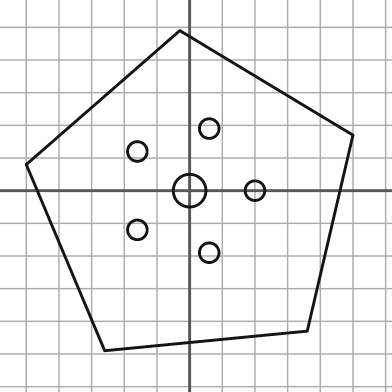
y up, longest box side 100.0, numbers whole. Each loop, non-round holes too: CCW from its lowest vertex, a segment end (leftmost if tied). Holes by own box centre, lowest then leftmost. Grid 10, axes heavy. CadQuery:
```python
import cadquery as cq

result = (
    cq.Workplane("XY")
    .moveTo(-26.0, -49.0)
    .lineTo(36.0, -43.0)
    .lineTo(50.0, 17.0)
    .lineTo(-3.0, 49.0)
    .lineTo(-50.0, 8.0)
    .close()
    .moveTo(6.0, -19.0)
    .circle(3.0)
    .moveTo(-16.0, -12.0)
    .circle(3.0)
    .moveTo(0.0, 0.0)
    .circle(5.0)
    .moveTo(20.0, 0.0)
    .circle(3.0)
    .moveTo(-16.0, 12.0)
    .circle(3.0)
    .moveTo(6.0, 19.0)
    .circle(3.0)
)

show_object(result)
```